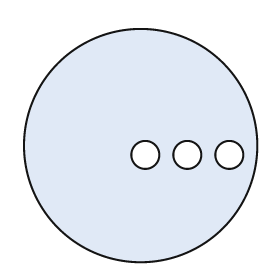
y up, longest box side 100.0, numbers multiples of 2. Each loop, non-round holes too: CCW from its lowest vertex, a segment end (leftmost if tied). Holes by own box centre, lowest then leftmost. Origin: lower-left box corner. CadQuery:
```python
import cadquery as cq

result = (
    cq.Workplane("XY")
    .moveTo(50.0, 50.0)
    .circle(50.0)
    .moveTo(52.0, 46.0)
    .circle(6.0)
    .moveTo(70.0, 46.0)
    .circle(6.0)
    .moveTo(88.0, 46.0)
    .circle(6.0)
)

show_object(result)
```